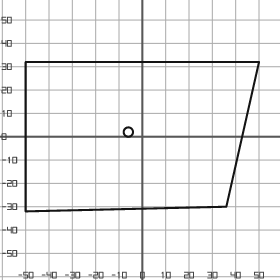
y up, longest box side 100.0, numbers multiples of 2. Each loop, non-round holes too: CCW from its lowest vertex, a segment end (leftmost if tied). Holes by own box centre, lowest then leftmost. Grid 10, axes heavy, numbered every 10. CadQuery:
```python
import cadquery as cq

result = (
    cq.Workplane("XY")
    .moveTo(-50.0, -32.0)
    .lineTo(36.0, -30.0)
    .lineTo(50.0, 32.0)
    .lineTo(-50.0, 32.0)
    .close()
    .moveTo(-6.0, 2.0)
    .circle(2.0)
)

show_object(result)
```